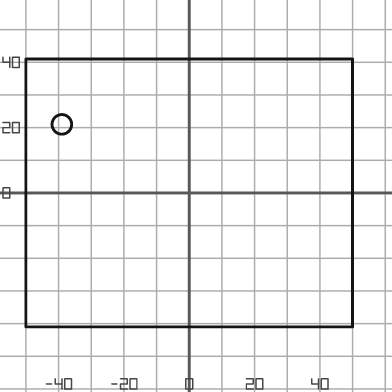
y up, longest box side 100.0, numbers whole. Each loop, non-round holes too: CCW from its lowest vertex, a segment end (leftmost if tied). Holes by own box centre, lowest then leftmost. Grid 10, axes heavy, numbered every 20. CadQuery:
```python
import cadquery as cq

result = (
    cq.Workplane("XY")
    .moveTo(-50.0, -41.0)
    .lineTo(50.0, -41.0)
    .lineTo(50.0, 41.0)
    .lineTo(-50.0, 41.0)
    .close()
    .moveTo(-39.0, 21.0)
    .circle(3.0)
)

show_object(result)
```